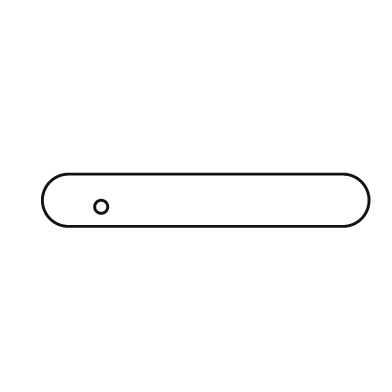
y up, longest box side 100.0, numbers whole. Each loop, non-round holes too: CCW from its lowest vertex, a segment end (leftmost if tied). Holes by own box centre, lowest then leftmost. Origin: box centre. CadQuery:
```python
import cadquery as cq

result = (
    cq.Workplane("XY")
    .moveTo(-42.0, -8.0)
    .lineTo(42.0, -8.0)
    .threePointArc((50.0, 0.0), (42.0, 8.0))
    .lineTo(-42.0, 8.0)
    .threePointArc((-50.0, 0.0), (-42.0, -8.0))
    .close()
    .moveTo(-32.0, -2.0)
    .circle(2.0)
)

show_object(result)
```